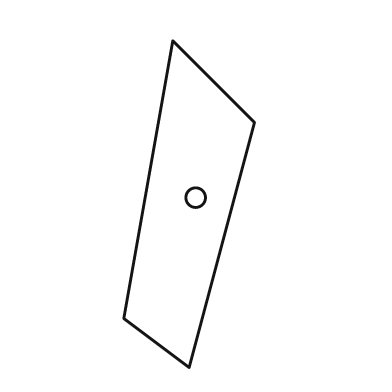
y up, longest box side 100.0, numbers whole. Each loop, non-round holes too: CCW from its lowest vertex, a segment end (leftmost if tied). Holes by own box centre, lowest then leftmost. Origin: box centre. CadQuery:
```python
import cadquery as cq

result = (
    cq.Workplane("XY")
    .moveTo(0.0, -50.0)
    .lineTo(20.0, 25.0)
    .lineTo(-5.0, 50.0)
    .lineTo(-20.0, -35.0)
    .close()
    .moveTo(2.0, 2.0)
    .circle(3.0)
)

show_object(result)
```